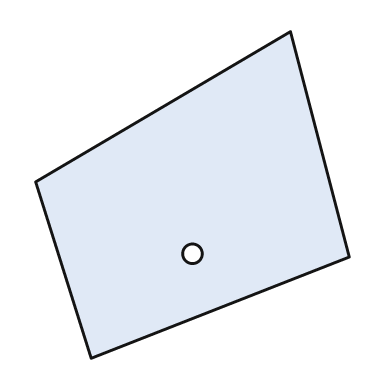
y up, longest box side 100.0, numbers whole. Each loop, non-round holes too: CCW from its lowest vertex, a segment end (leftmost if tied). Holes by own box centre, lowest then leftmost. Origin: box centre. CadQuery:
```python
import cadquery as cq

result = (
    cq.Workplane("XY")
    .moveTo(-31.0, -50.0)
    .lineTo(48.0, -19.0)
    .lineTo(30.0, 50.0)
    .lineTo(-48.0, 4.0)
    .close()
    .moveTo(0.0, -18.0)
    .circle(3.0)
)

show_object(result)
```